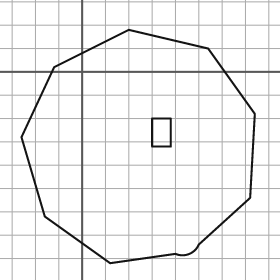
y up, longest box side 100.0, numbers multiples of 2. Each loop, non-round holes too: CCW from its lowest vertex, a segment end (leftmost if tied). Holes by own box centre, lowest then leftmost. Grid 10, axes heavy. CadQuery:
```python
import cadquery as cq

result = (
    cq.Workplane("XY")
    .moveTo(12.0, -82.0)
    .lineTo(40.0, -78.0)
    .threePointArc((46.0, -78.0), (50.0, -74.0))
    .lineTo(72.0, -54.0)
    .lineTo(74.0, -18.0)
    .lineTo(54.0, 10.0)
    .lineTo(20.0, 18.0)
    .lineTo(-12.0, 2.0)
    .lineTo(-26.0, -28.0)
    .lineTo(-16.0, -62.0)
    .close()
    .moveTo(30.0, -32.0)
    .lineTo(38.0, -32.0)
    .lineTo(38.0, -20.0)
    .lineTo(30.0, -20.0)
    .close()
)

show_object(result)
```